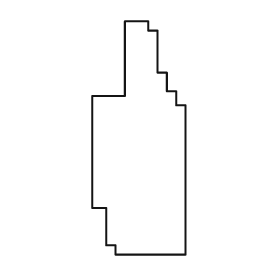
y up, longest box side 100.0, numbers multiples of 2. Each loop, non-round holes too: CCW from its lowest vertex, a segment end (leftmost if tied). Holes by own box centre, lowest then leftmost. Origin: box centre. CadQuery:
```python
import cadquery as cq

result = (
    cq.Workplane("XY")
    .moveTo(-10.0, -50.0)
    .lineTo(20.0, -50.0)
    .lineTo(20.0, 14.0)
    .lineTo(16.0, 14.0)
    .lineTo(16.0, 20.0)
    .lineTo(12.0, 20.0)
    .lineTo(12.0, 28.0)
    .lineTo(8.0, 28.0)
    .lineTo(8.0, 46.0)
    .lineTo(4.0, 46.0)
    .lineTo(4.0, 50.0)
    .lineTo(-6.0, 50.0)
    .lineTo(-6.0, 18.0)
    .lineTo(-20.0, 18.0)
    .lineTo(-20.0, -30.0)
    .lineTo(-14.0, -30.0)
    .lineTo(-14.0, -46.0)
    .lineTo(-10.0, -46.0)
    .close()
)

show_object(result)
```